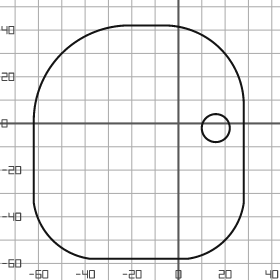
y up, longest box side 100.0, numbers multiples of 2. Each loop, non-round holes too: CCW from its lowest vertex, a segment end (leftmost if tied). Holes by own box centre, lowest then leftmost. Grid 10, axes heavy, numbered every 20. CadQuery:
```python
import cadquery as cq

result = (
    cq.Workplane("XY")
    .moveTo(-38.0, -58.0)
    .lineTo(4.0, -58.0)
    .threePointArc((20.0, -50.0), (28.0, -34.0))
    .lineTo(28.0, 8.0)
    .threePointArc((18.0, 32.0), (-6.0, 42.0))
    .lineTo(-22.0, 42.0)
    .threePointArc((-50.0, 30.0), (-62.0, 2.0))
    .lineTo(-62.0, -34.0)
    .threePointArc((-54.0, -50.0), (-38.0, -58.0))
    .close()
    .moveTo(16.0, -2.0)
    .circle(6.0)
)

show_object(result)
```